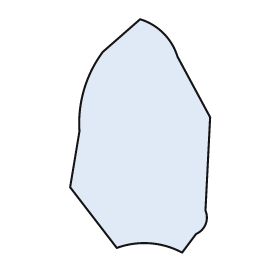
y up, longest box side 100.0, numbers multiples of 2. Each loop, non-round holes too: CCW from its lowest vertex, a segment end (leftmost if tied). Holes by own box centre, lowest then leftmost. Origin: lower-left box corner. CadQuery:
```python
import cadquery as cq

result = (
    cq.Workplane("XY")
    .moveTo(48.0, 0.0)
    .lineTo(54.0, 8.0)
    .threePointArc((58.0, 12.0), (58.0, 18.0))
    .lineTo(60.0, 58.0)
    .lineTo(46.0, 84.0)
    .threePointArc((40.0, 94.0), (30.0, 100.0))
    .lineTo(14.0, 86.0)
    .threePointArc((6.0, 70.0), (4.0, 52.0))
    .lineTo(0.0, 28.0)
    .lineTo(20.0, 2.0)
    .threePointArc((34.0, 4.0), (48.0, 0.0))
    .close()
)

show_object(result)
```